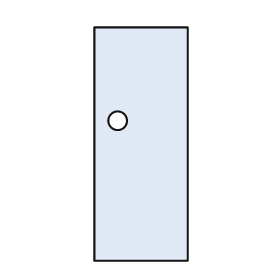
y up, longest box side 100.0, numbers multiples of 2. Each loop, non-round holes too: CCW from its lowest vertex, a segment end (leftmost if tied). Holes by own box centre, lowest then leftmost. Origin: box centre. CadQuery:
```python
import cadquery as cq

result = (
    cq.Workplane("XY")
    .moveTo(-20.0, -50.0)
    .lineTo(20.0, -50.0)
    .lineTo(20.0, 50.0)
    .lineTo(-20.0, 50.0)
    .close()
    .moveTo(-10.0, 10.0)
    .circle(4.0)
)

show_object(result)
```